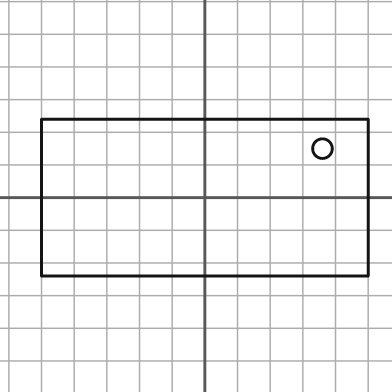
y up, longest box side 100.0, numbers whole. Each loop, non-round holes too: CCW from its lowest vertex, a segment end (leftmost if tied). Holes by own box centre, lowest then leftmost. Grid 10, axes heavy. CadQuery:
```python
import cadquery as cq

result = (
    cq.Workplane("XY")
    .moveTo(-50.0, -24.0)
    .lineTo(50.0, -24.0)
    .lineTo(50.0, 24.0)
    .lineTo(-50.0, 24.0)
    .close()
    .moveTo(36.0, 15.0)
    .circle(3.0)
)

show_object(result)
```